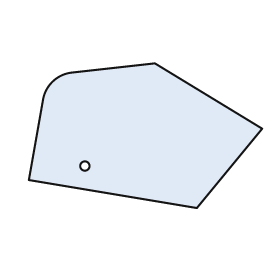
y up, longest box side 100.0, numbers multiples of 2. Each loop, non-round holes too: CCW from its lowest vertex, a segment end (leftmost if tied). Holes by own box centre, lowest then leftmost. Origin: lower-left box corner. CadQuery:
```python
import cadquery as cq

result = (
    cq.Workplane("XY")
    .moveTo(72.0, 0.0)
    .lineTo(100.0, 34.0)
    .lineTo(54.0, 62.0)
    .lineTo(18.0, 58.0)
    .threePointArc((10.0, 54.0), (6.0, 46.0))
    .lineTo(0.0, 12.0)
    .close()
    .moveTo(24.0, 18.0)
    .circle(2.0)
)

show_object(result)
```